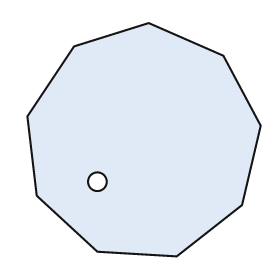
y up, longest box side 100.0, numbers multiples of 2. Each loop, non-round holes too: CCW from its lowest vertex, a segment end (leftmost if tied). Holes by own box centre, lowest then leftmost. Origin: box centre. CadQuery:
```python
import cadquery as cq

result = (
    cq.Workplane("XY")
    .moveTo(14.0, -50.0)
    .lineTo(42.0, -28.0)
    .lineTo(50.0, 6.0)
    .lineTo(34.0, 36.0)
    .lineTo(2.0, 50.0)
    .lineTo(-30.0, 40.0)
    .lineTo(-50.0, 10.0)
    .lineTo(-46.0, -24.0)
    .lineTo(-20.0, -48.0)
    .close()
    .moveTo(-20.0, -18.0)
    .circle(4.0)
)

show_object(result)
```